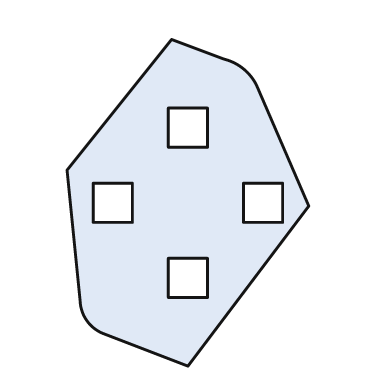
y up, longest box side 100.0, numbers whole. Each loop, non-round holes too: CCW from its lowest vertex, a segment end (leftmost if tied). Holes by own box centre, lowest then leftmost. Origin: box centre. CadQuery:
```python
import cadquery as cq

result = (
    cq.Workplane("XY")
    .moveTo(0.0, -50.0)
    .lineTo(37.0, -1.0)
    .lineTo(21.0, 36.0)
    .threePointArc((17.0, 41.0), (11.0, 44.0))
    .lineTo(-5.0, 50.0)
    .lineTo(-37.0, 10.0)
    .lineTo(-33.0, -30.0)
    .threePointArc((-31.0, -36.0), (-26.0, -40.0))
    .close()
    .moveTo(-6.0, -29.0)
    .lineTo(6.0, -29.0)
    .lineTo(6.0, -17.0)
    .lineTo(-6.0, -17.0)
    .close()
    .moveTo(-29.0, -6.0)
    .lineTo(-17.0, -6.0)
    .lineTo(-17.0, 6.0)
    .lineTo(-29.0, 6.0)
    .close()
    .moveTo(17.0, -6.0)
    .lineTo(29.0, -6.0)
    .lineTo(29.0, 6.0)
    .lineTo(17.0, 6.0)
    .close()
    .moveTo(-6.0, 17.0)
    .lineTo(6.0, 17.0)
    .lineTo(6.0, 29.0)
    .lineTo(-6.0, 29.0)
    .close()
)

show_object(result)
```